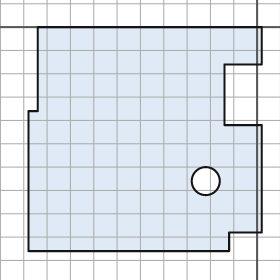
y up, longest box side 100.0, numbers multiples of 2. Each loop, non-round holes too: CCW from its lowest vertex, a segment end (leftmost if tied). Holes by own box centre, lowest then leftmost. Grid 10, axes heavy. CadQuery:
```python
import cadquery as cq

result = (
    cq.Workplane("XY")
    .moveTo(-98.0, -96.0)
    .lineTo(-12.0, -96.0)
    .lineTo(-12.0, -88.0)
    .lineTo(2.0, -88.0)
    .lineTo(2.0, -42.0)
    .lineTo(-14.0, -42.0)
    .lineTo(-14.0, -16.0)
    .lineTo(2.0, -16.0)
    .lineTo(2.0, 0.0)
    .lineTo(-94.0, 0.0)
    .lineTo(-94.0, -36.0)
    .lineTo(-98.0, -36.0)
    .close()
    .moveTo(-22.0, -66.0)
    .circle(6.0)
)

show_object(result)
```